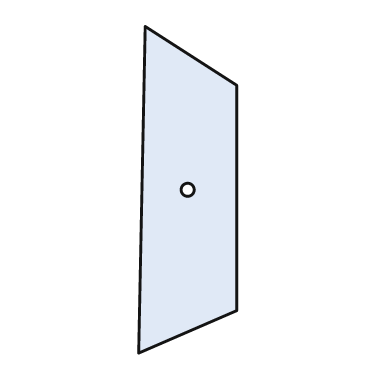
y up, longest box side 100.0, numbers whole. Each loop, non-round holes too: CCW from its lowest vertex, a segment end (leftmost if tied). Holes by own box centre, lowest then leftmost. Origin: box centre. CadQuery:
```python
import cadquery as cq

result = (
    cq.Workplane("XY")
    .moveTo(-15.0, -50.0)
    .lineTo(15.0, -37.0)
    .lineTo(15.0, 32.0)
    .lineTo(-13.0, 50.0)
    .close()
    .moveTo(0.0, 0.0)
    .circle(2.0)
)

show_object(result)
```